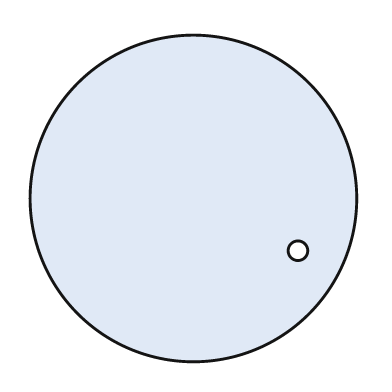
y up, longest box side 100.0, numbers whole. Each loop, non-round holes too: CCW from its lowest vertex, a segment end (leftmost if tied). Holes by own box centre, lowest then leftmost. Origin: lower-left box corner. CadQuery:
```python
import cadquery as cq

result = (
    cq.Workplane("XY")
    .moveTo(50.0, 50.0)
    .circle(50.0)
    .moveTo(82.0, 34.0)
    .circle(3.0)
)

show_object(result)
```